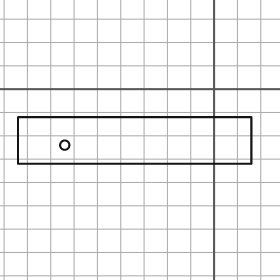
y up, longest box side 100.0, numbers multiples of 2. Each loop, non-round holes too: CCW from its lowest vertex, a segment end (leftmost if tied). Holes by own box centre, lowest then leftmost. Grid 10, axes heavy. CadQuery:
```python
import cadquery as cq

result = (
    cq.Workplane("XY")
    .moveTo(-84.0, -32.0)
    .lineTo(16.0, -32.0)
    .lineTo(16.0, -12.0)
    .lineTo(-84.0, -12.0)
    .close()
    .moveTo(-64.0, -24.0)
    .circle(2.0)
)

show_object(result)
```